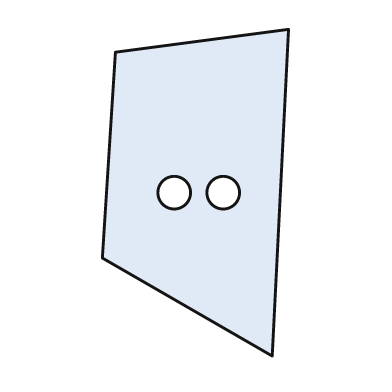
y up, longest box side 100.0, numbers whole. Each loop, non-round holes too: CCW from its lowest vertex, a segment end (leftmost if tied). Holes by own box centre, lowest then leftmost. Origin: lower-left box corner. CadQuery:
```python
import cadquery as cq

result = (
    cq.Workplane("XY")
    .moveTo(52.0, 0.0)
    .lineTo(57.0, 100.0)
    .lineTo(4.0, 93.0)
    .lineTo(0.0, 30.0)
    .close()
    .moveTo(22.0, 50.0)
    .circle(5.0)
    .moveTo(37.0, 50.0)
    .circle(5.0)
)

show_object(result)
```